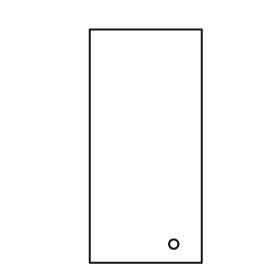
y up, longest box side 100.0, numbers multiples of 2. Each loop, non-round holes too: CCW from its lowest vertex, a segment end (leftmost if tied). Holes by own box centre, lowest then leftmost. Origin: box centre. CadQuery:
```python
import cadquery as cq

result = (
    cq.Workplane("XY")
    .moveTo(-24.0, -50.0)
    .lineTo(24.0, -50.0)
    .lineTo(24.0, 50.0)
    .lineTo(-24.0, 50.0)
    .close()
    .moveTo(12.0, -42.0)
    .circle(2.0)
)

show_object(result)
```